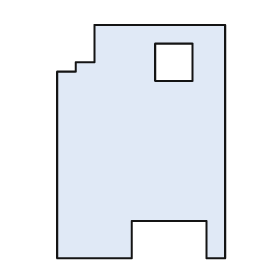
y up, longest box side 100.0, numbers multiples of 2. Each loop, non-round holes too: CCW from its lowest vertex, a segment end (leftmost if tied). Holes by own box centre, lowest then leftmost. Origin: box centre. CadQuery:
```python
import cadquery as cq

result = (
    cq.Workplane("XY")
    .moveTo(-36.0, -50.0)
    .lineTo(-4.0, -50.0)
    .lineTo(-4.0, -34.0)
    .lineTo(28.0, -34.0)
    .lineTo(28.0, -50.0)
    .lineTo(36.0, -50.0)
    .lineTo(36.0, 50.0)
    .lineTo(-20.0, 50.0)
    .lineTo(-20.0, 34.0)
    .lineTo(-28.0, 34.0)
    .lineTo(-28.0, 30.0)
    .lineTo(-36.0, 30.0)
    .close()
    .moveTo(6.0, 26.0)
    .lineTo(22.0, 26.0)
    .lineTo(22.0, 42.0)
    .lineTo(6.0, 42.0)
    .close()
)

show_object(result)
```